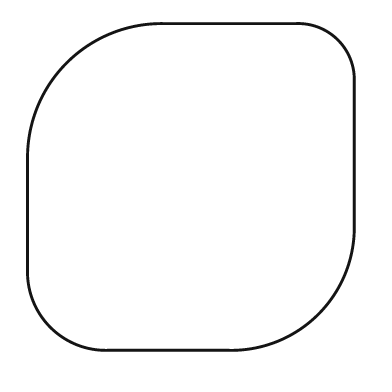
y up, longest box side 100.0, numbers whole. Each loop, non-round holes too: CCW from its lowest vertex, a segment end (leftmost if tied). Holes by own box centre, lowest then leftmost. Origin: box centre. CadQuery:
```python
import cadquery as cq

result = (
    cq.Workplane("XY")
    .moveTo(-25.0, -50.0)
    .lineTo(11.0, -50.0)
    .threePointArc((39.0, -39.0), (50.0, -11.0))
    .lineTo(50.0, 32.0)
    .threePointArc((45.0, 45.0), (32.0, 50.0))
    .lineTo(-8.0, 50.0)
    .threePointArc((-38.0, 38.0), (-50.0, 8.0))
    .lineTo(-50.0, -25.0)
    .threePointArc((-43.0, -43.0), (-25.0, -50.0))
    .close()
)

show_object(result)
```